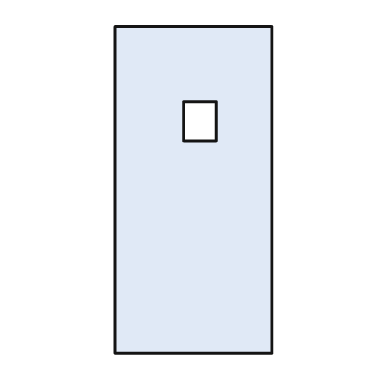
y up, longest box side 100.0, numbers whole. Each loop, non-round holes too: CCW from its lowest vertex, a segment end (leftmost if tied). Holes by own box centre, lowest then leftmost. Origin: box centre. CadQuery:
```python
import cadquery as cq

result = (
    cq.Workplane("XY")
    .moveTo(-24.0, -50.0)
    .lineTo(24.0, -50.0)
    .lineTo(24.0, 50.0)
    .lineTo(-24.0, 50.0)
    .close()
    .moveTo(-3.0, 15.0)
    .lineTo(7.0, 15.0)
    .lineTo(7.0, 27.0)
    .lineTo(-3.0, 27.0)
    .close()
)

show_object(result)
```